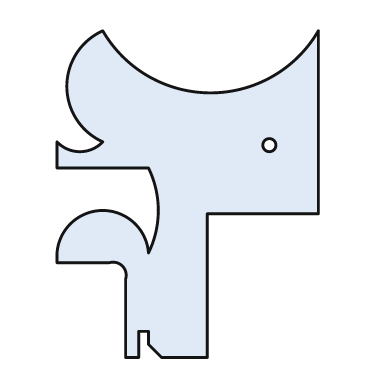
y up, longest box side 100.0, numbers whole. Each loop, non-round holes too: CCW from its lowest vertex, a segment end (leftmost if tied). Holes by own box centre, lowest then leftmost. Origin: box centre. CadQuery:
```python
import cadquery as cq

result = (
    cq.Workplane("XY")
    .moveTo(-19.0, -50.0)
    .lineTo(-15.0, -50.0)
    .lineTo(-15.0, -42.0)
    .lineTo(-12.0, -42.0)
    .lineTo(-12.0, -46.0)
    .lineTo(-8.0, -50.0)
    .lineTo(6.0, -50.0)
    .lineTo(6.0, -6.0)
    .lineTo(40.0, -6.0)
    .lineTo(40.0, 50.0)
    .threePointArc((7.0, 31.0), (-26.0, 50.0))
    .threePointArc((-37.0, 33.0), (-26.0, 16.0))
    .threePointArc((-33.0, 13.0), (-40.0, 16.0))
    .lineTo(-40.0, 8.0)
    .lineTo(-12.0, 8.0)
    .threePointArc((-9.0, -5.0), (-12.0, -18.0))
    .threePointArc((-26.0, -5.0), (-40.0, -18.0))
    .lineTo(-40.0, -21.0)
    .lineTo(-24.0, -21.0)
    .threePointArc((-20.0, -22.0), (-19.0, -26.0))
    .close()
    .moveTo(25.0, 15.0)
    .circle(2.0)
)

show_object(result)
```